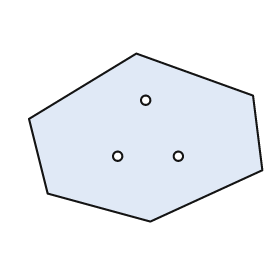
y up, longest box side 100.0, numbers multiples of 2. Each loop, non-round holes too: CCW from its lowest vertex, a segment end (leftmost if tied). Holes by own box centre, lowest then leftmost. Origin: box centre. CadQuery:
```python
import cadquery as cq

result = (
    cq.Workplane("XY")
    .moveTo(2.0, -36.0)
    .lineTo(50.0, -14.0)
    .lineTo(46.0, 18.0)
    .lineTo(-4.0, 36.0)
    .lineTo(-50.0, 8.0)
    .lineTo(-42.0, -24.0)
    .close()
    .moveTo(-12.0, -8.0)
    .circle(2.0)
    .moveTo(14.0, -8.0)
    .circle(2.0)
    .moveTo(0.0, 16.0)
    .circle(2.0)
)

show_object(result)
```